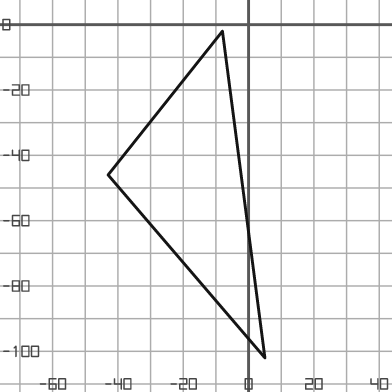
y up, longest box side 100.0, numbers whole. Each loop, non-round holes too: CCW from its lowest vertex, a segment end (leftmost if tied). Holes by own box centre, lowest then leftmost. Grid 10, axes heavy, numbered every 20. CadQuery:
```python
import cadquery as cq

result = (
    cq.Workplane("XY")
    .moveTo(5.0, -102.0)
    .lineTo(-8.0, -2.0)
    .lineTo(-43.0, -46.0)
    .close()
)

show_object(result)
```